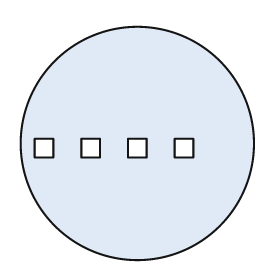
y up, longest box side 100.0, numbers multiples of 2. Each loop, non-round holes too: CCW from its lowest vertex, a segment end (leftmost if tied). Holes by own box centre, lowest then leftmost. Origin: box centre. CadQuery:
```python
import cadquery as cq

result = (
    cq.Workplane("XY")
    .moveTo(0.0, 0.0)
    .circle(50.0)
    .moveTo(-44.0, -6.0)
    .lineTo(-36.0, -6.0)
    .lineTo(-36.0, 2.0)
    .lineTo(-44.0, 2.0)
    .close()
    .moveTo(-24.0, -6.0)
    .lineTo(-16.0, -6.0)
    .lineTo(-16.0, 2.0)
    .lineTo(-24.0, 2.0)
    .close()
    .moveTo(-4.0, -6.0)
    .lineTo(4.0, -6.0)
    .lineTo(4.0, 2.0)
    .lineTo(-4.0, 2.0)
    .close()
    .moveTo(16.0, -6.0)
    .lineTo(24.0, -6.0)
    .lineTo(24.0, 2.0)
    .lineTo(16.0, 2.0)
    .close()
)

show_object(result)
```